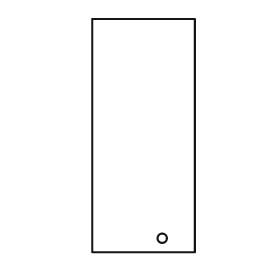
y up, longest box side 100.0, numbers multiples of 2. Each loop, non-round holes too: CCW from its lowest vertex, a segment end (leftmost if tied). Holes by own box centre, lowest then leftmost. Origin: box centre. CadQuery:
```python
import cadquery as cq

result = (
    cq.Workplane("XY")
    .moveTo(-22.0, -50.0)
    .lineTo(22.0, -50.0)
    .lineTo(22.0, 50.0)
    .lineTo(-22.0, 50.0)
    .close()
    .moveTo(8.0, -44.0)
    .circle(2.0)
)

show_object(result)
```